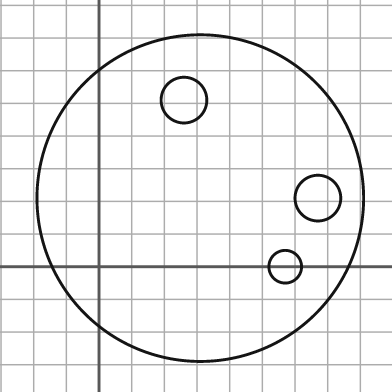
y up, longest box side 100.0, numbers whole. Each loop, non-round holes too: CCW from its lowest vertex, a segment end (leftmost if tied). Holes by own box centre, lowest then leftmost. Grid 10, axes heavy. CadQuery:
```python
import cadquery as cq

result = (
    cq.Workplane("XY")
    .moveTo(31.0, 21.0)
    .circle(50.0)
    .moveTo(57.0, 0.0)
    .circle(5.0)
    .moveTo(67.0, 21.0)
    .circle(7.0)
    .moveTo(26.0, 51.0)
    .circle(7.0)
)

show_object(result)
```